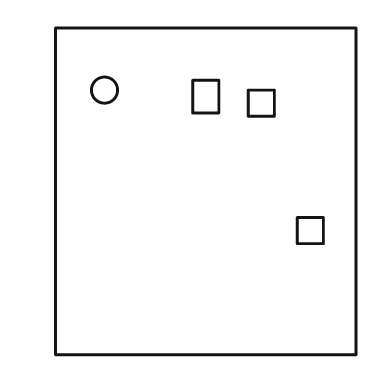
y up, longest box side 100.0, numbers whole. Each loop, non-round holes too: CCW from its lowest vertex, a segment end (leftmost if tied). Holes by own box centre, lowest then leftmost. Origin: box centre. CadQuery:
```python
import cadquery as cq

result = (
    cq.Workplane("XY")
    .moveTo(-46.0, -50.0)
    .lineTo(46.0, -50.0)
    .lineTo(46.0, 50.0)
    .lineTo(-46.0, 50.0)
    .close()
    .moveTo(28.0, -16.0)
    .lineTo(36.0, -16.0)
    .lineTo(36.0, -8.0)
    .lineTo(28.0, -8.0)
    .close()
    .moveTo(13.0, 23.0)
    .lineTo(21.0, 23.0)
    .lineTo(21.0, 31.0)
    .lineTo(13.0, 31.0)
    .close()
    .moveTo(-4.0, 24.0)
    .lineTo(4.0, 24.0)
    .lineTo(4.0, 34.0)
    .lineTo(-4.0, 34.0)
    .close()
    .moveTo(-31.0, 31.0)
    .circle(4.0)
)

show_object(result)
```